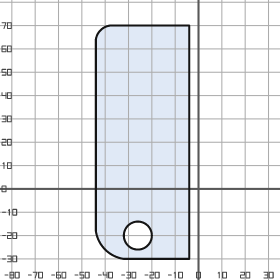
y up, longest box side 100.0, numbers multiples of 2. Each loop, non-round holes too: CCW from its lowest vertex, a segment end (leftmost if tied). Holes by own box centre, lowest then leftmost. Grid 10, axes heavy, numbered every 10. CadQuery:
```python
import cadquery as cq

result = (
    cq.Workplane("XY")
    .moveTo(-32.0, -30.0)
    .lineTo(-4.0, -30.0)
    .lineTo(-4.0, 70.0)
    .lineTo(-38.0, 70.0)
    .threePointArc((-42.0, 68.0), (-44.0, 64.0))
    .lineTo(-44.0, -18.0)
    .threePointArc((-40.0, -26.0), (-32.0, -30.0))
    .close()
    .moveTo(-26.0, -20.0)
    .circle(6.0)
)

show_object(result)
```